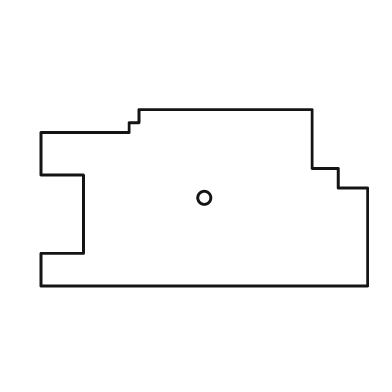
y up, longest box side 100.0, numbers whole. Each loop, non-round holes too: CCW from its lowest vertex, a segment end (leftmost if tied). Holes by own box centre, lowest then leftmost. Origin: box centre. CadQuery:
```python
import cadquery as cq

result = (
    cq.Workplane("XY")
    .moveTo(-50.0, -27.0)
    .lineTo(50.0, -27.0)
    .lineTo(50.0, 3.0)
    .lineTo(41.0, 3.0)
    .lineTo(41.0, 9.0)
    .lineTo(33.0, 9.0)
    .lineTo(33.0, 27.0)
    .lineTo(-20.0, 27.0)
    .lineTo(-20.0, 23.0)
    .lineTo(-23.0, 23.0)
    .lineTo(-23.0, 20.0)
    .lineTo(-50.0, 20.0)
    .lineTo(-50.0, 7.0)
    .lineTo(-37.0, 7.0)
    .lineTo(-37.0, -17.0)
    .lineTo(-50.0, -17.0)
    .close()
    .moveTo(0.0, 0.0)
    .circle(2.0)
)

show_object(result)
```